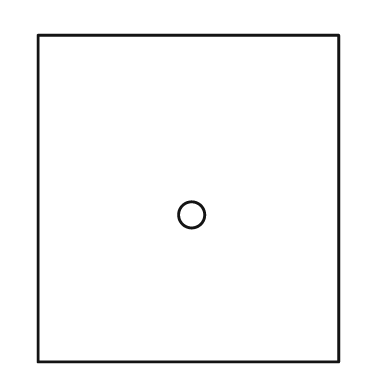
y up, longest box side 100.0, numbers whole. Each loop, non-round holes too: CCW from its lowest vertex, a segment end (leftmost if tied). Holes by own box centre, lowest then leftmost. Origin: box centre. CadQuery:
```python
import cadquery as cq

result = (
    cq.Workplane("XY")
    .moveTo(-46.0, -50.0)
    .lineTo(46.0, -50.0)
    .lineTo(46.0, 50.0)
    .lineTo(-46.0, 50.0)
    .close()
    .moveTo(1.0, -5.0)
    .circle(4.0)
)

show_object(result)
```